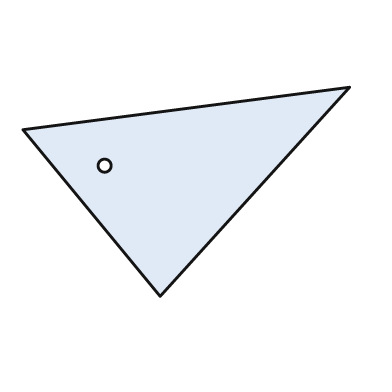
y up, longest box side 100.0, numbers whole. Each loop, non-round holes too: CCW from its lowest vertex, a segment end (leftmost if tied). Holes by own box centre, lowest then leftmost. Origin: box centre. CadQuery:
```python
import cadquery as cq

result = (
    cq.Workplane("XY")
    .moveTo(-8.0, -32.0)
    .lineTo(50.0, 32.0)
    .lineTo(-50.0, 19.0)
    .close()
    .moveTo(-25.0, 8.0)
    .circle(2.0)
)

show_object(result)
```